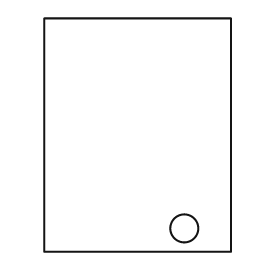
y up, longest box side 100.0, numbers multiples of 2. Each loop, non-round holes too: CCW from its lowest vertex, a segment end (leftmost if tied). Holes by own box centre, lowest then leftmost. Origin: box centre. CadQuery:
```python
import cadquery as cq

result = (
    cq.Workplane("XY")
    .moveTo(-40.0, -50.0)
    .lineTo(40.0, -50.0)
    .lineTo(40.0, 50.0)
    .lineTo(-40.0, 50.0)
    .close()
    .moveTo(20.0, -40.0)
    .circle(6.0)
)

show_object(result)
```